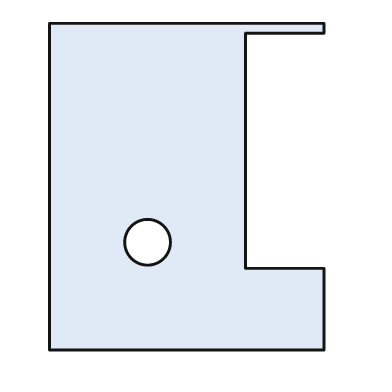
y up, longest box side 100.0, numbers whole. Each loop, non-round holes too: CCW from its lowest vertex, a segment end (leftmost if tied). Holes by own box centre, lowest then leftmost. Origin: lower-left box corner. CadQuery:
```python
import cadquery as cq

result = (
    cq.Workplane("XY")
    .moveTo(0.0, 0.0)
    .lineTo(84.0, 0.0)
    .lineTo(84.0, 25.0)
    .lineTo(60.0, 25.0)
    .lineTo(60.0, 97.0)
    .lineTo(84.0, 97.0)
    .lineTo(84.0, 100.0)
    .lineTo(0.0, 100.0)
    .close()
    .moveTo(30.0, 33.0)
    .circle(7.0)
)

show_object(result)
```